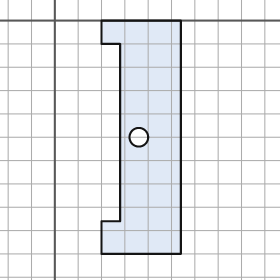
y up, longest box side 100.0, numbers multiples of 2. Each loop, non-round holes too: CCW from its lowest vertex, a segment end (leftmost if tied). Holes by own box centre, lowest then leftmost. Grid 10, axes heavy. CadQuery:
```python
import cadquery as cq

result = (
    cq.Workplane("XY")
    .moveTo(20.0, -100.0)
    .lineTo(54.0, -100.0)
    .lineTo(54.0, 0.0)
    .lineTo(20.0, 0.0)
    .lineTo(20.0, -10.0)
    .lineTo(28.0, -10.0)
    .lineTo(28.0, -86.0)
    .lineTo(20.0, -86.0)
    .close()
    .moveTo(36.0, -50.0)
    .circle(4.0)
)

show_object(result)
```